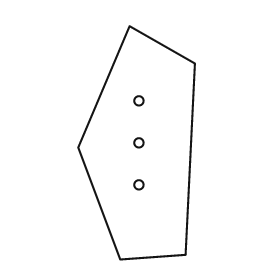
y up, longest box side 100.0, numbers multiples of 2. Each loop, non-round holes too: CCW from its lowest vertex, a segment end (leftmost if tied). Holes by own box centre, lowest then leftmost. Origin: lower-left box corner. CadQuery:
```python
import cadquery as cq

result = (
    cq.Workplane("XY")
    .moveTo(18.0, 0.0)
    .lineTo(46.0, 2.0)
    .lineTo(50.0, 84.0)
    .lineTo(22.0, 100.0)
    .lineTo(0.0, 48.0)
    .close()
    .moveTo(26.0, 32.0)
    .circle(2.0)
    .moveTo(26.0, 50.0)
    .circle(2.0)
    .moveTo(26.0, 68.0)
    .circle(2.0)
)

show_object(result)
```